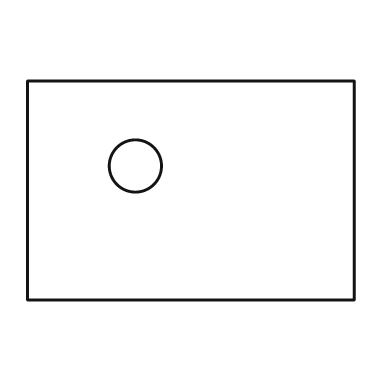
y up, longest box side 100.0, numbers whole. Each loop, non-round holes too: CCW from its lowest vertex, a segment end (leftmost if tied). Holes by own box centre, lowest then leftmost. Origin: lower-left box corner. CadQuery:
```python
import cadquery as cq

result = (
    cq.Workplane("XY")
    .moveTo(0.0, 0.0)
    .lineTo(100.0, 0.0)
    .lineTo(100.0, 67.0)
    .lineTo(0.0, 67.0)
    .close()
    .moveTo(33.0, 41.0)
    .circle(8.0)
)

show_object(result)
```